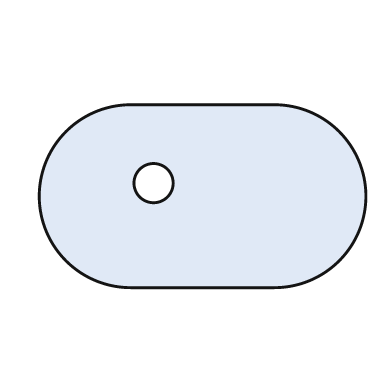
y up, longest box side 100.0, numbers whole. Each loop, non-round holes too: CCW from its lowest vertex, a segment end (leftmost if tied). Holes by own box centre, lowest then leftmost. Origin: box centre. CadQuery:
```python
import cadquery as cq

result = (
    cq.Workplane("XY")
    .moveTo(-22.0, -28.0)
    .lineTo(22.0, -28.0)
    .threePointArc((50.0, 0.0), (22.0, 28.0))
    .lineTo(-22.0, 28.0)
    .threePointArc((-50.0, 0.0), (-22.0, -28.0))
    .close()
    .moveTo(-15.0, 4.0)
    .circle(6.0)
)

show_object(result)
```